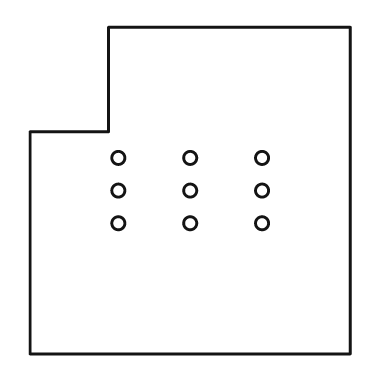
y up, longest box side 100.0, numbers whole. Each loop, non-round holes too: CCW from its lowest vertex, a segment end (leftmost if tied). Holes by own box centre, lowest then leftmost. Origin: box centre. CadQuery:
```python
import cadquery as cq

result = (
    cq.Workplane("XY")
    .moveTo(-49.0, -50.0)
    .lineTo(49.0, -50.0)
    .lineTo(49.0, 50.0)
    .lineTo(-25.0, 50.0)
    .lineTo(-25.0, 18.0)
    .lineTo(-49.0, 18.0)
    .close()
    .moveTo(-22.0, -10.0)
    .circle(2.0)
    .moveTo(0.0, -10.0)
    .circle(2.0)
    .moveTo(22.0, -10.0)
    .circle(2.0)
    .moveTo(-22.0, 0.0)
    .circle(2.0)
    .moveTo(0.0, 0.0)
    .circle(2.0)
    .moveTo(22.0, 0.0)
    .circle(2.0)
    .moveTo(-22.0, 10.0)
    .circle(2.0)
    .moveTo(0.0, 10.0)
    .circle(2.0)
    .moveTo(22.0, 10.0)
    .circle(2.0)
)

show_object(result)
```